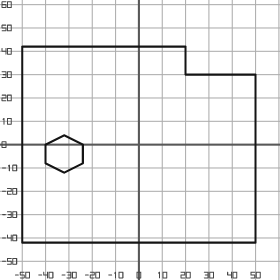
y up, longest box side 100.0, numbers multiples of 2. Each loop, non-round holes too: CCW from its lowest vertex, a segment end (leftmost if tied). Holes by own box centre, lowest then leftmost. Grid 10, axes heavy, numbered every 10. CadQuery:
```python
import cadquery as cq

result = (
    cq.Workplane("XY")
    .moveTo(-50.0, -42.0)
    .lineTo(50.0, -42.0)
    .lineTo(50.0, 30.0)
    .lineTo(20.0, 30.0)
    .lineTo(20.0, 42.0)
    .lineTo(-50.0, 42.0)
    .close()
    .moveTo(-32.0, -12.0)
    .lineTo(-24.0, -8.0)
    .lineTo(-24.0, 0.0)
    .lineTo(-32.0, 4.0)
    .lineTo(-40.0, 0.0)
    .lineTo(-40.0, -8.0)
    .close()
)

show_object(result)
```